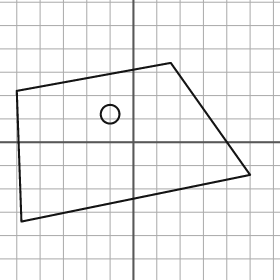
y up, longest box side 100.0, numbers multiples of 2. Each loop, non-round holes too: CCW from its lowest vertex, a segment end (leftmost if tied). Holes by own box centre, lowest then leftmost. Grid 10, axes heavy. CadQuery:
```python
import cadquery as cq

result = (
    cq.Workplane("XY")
    .moveTo(-48.0, -34.0)
    .lineTo(50.0, -14.0)
    .lineTo(16.0, 34.0)
    .lineTo(-50.0, 22.0)
    .close()
    .moveTo(-10.0, 12.0)
    .circle(4.0)
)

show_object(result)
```